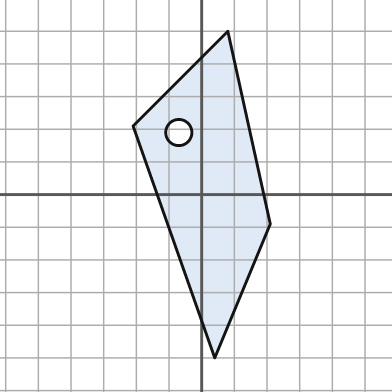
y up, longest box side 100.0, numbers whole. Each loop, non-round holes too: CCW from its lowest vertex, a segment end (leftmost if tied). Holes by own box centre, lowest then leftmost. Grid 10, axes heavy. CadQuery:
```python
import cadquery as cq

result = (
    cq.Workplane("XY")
    .moveTo(4.0, -50.0)
    .lineTo(21.0, -9.0)
    .lineTo(8.0, 50.0)
    .lineTo(-21.0, 21.0)
    .close()
    .moveTo(-7.0, 19.0)
    .circle(4.0)
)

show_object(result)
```